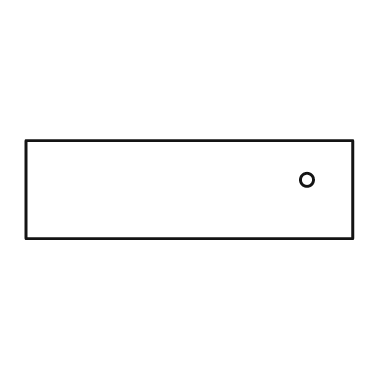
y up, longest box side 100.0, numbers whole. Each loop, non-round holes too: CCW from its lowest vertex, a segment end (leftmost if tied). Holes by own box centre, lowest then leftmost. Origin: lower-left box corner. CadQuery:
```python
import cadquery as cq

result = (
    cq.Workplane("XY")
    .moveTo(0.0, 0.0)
    .lineTo(100.0, 0.0)
    .lineTo(100.0, 30.0)
    .lineTo(0.0, 30.0)
    .close()
    .moveTo(86.0, 18.0)
    .circle(2.0)
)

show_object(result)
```